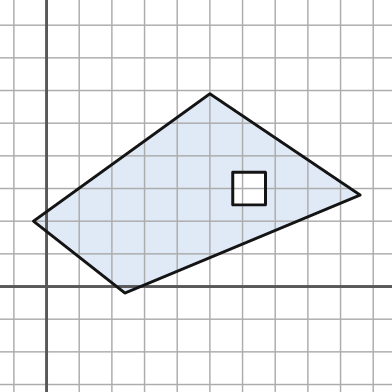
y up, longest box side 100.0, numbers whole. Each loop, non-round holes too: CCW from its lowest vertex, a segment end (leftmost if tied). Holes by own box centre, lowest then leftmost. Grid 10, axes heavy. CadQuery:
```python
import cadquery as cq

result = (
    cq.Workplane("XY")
    .moveTo(24.0, -2.0)
    .lineTo(96.0, 28.0)
    .lineTo(50.0, 59.0)
    .lineTo(-4.0, 20.0)
    .close()
    .moveTo(57.0, 25.0)
    .lineTo(67.0, 25.0)
    .lineTo(67.0, 35.0)
    .lineTo(57.0, 35.0)
    .close()
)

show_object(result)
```